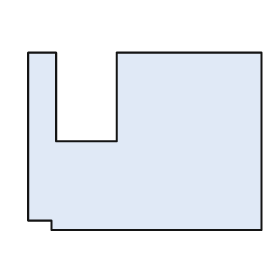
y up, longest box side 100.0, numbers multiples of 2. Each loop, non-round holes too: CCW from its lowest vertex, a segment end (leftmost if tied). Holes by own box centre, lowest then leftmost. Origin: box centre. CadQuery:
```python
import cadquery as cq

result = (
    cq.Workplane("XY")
    .moveTo(-40.0, -38.0)
    .lineTo(50.0, -38.0)
    .lineTo(50.0, 38.0)
    .lineTo(-12.0, 38.0)
    .lineTo(-12.0, 0.0)
    .lineTo(-38.0, 0.0)
    .lineTo(-38.0, 38.0)
    .lineTo(-50.0, 38.0)
    .lineTo(-50.0, -34.0)
    .lineTo(-40.0, -34.0)
    .close()
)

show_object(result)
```